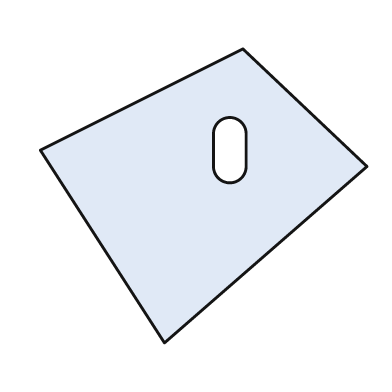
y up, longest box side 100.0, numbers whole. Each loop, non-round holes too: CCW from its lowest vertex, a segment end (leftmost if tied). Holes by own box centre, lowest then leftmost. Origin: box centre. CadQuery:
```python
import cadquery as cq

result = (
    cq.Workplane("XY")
    .moveTo(-12.0, -45.0)
    .lineTo(50.0, 9.0)
    .lineTo(12.0, 45.0)
    .lineTo(-50.0, 14.0)
    .close()
    .moveTo(3.0, 9.0)
    .threePointArc((8.0, 4.0), (13.0, 9.0))
    .lineTo(13.0, 19.0)
    .threePointArc((8.0, 24.0), (3.0, 19.0))
    .close()
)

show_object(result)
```